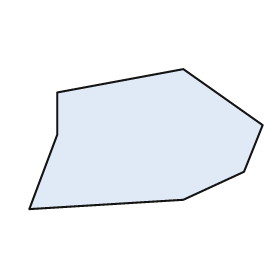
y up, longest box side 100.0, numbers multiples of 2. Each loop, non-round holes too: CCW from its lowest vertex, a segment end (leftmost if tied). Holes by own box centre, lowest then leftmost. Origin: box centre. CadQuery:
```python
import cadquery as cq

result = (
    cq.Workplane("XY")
    .moveTo(-50.0, -30.0)
    .lineTo(16.0, -26.0)
    .lineTo(42.0, -14.0)
    .lineTo(50.0, 6.0)
    .lineTo(16.0, 30.0)
    .lineTo(-38.0, 20.0)
    .lineTo(-38.0, 2.0)
    .close()
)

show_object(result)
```